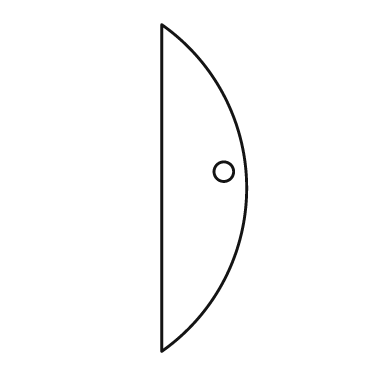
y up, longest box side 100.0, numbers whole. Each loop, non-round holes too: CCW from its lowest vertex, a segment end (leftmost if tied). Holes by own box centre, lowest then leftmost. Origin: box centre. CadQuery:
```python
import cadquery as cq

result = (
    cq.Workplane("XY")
    .moveTo(-13.0, -50.0)
    .threePointArc((13.0, 0.0), (-13.0, 50.0))
    .close()
    .moveTo(6.0, 5.0)
    .circle(3.0)
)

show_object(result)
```